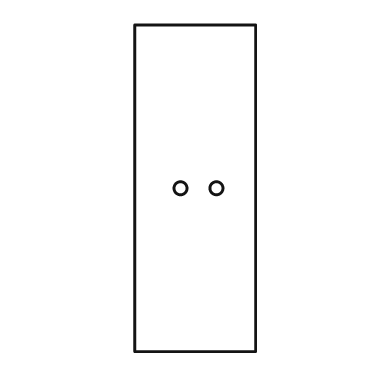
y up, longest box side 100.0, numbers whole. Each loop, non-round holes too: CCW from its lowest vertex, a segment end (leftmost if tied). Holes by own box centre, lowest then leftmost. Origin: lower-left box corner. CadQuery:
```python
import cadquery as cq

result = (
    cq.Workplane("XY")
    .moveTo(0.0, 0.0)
    .lineTo(37.0, 0.0)
    .lineTo(37.0, 100.0)
    .lineTo(0.0, 100.0)
    .close()
    .moveTo(14.0, 50.0)
    .circle(2.0)
    .moveTo(25.0, 50.0)
    .circle(2.0)
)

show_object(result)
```